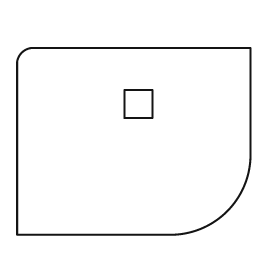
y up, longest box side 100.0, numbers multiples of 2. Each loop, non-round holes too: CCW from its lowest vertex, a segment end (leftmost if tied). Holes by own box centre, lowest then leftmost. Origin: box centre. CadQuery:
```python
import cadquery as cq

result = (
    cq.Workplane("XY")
    .moveTo(-50.0, -40.0)
    .lineTo(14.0, -40.0)
    .threePointArc((40.0, -30.0), (50.0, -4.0))
    .lineTo(50.0, 40.0)
    .lineTo(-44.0, 40.0)
    .threePointArc((-48.0, 38.0), (-50.0, 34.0))
    .close()
    .moveTo(-4.0, 10.0)
    .lineTo(8.0, 10.0)
    .lineTo(8.0, 22.0)
    .lineTo(-4.0, 22.0)
    .close()
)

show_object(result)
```